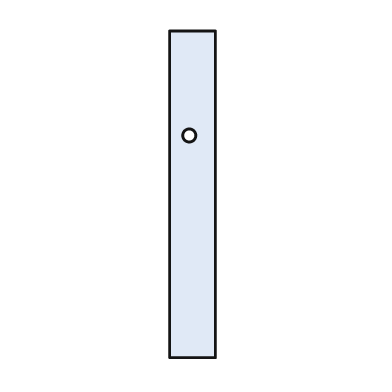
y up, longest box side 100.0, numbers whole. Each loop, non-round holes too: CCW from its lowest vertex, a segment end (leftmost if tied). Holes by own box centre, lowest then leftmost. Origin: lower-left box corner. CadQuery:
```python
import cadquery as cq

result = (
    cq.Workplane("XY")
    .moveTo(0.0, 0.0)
    .lineTo(14.0, 0.0)
    .lineTo(14.0, 100.0)
    .lineTo(0.0, 100.0)
    .close()
    .moveTo(6.0, 68.0)
    .circle(2.0)
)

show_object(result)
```